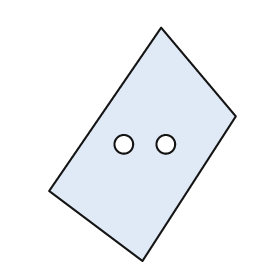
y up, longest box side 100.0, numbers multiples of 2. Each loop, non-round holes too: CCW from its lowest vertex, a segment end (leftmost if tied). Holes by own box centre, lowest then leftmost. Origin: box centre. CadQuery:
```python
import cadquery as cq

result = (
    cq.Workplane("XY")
    .moveTo(0.0, -50.0)
    .lineTo(40.0, 12.0)
    .lineTo(8.0, 50.0)
    .lineTo(-40.0, -20.0)
    .close()
    .moveTo(-8.0, 0.0)
    .circle(4.0)
    .moveTo(10.0, 0.0)
    .circle(4.0)
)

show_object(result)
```